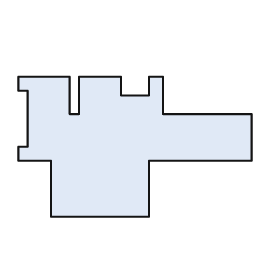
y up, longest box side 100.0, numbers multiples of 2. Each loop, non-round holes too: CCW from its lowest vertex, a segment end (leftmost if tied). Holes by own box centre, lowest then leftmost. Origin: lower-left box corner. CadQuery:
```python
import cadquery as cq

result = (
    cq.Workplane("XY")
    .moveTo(14.0, 0.0)
    .lineTo(56.0, 0.0)
    .lineTo(56.0, 24.0)
    .lineTo(100.0, 24.0)
    .lineTo(100.0, 44.0)
    .lineTo(62.0, 44.0)
    .lineTo(62.0, 60.0)
    .lineTo(56.0, 60.0)
    .lineTo(56.0, 52.0)
    .lineTo(44.0, 52.0)
    .lineTo(44.0, 60.0)
    .lineTo(26.0, 60.0)
    .lineTo(26.0, 44.0)
    .lineTo(22.0, 44.0)
    .lineTo(22.0, 60.0)
    .lineTo(0.0, 60.0)
    .lineTo(0.0, 54.0)
    .lineTo(4.0, 54.0)
    .lineTo(4.0, 30.0)
    .lineTo(0.0, 30.0)
    .lineTo(0.0, 24.0)
    .lineTo(14.0, 24.0)
    .close()
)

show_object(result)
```